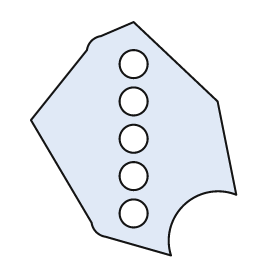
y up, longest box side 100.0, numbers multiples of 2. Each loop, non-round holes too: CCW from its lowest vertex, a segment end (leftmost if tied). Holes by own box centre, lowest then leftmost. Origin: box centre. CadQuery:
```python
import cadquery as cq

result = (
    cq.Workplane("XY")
    .moveTo(16.0, -50.0)
    .threePointArc((22.0, -28.0), (44.0, -24.0))
    .lineTo(36.0, 16.0)
    .lineTo(0.0, 50.0)
    .lineTo(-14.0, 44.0)
    .threePointArc((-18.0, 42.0), (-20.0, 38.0))
    .lineTo(-44.0, 8.0)
    .lineTo(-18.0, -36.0)
    .threePointArc((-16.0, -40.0), (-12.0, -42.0))
    .close()
    .moveTo(0.0, -32.0)
    .circle(6.0)
    .moveTo(0.0, -16.0)
    .circle(6.0)
    .moveTo(0.0, 0.0)
    .circle(6.0)
    .moveTo(0.0, 16.0)
    .circle(6.0)
    .moveTo(0.0, 32.0)
    .circle(6.0)
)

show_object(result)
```